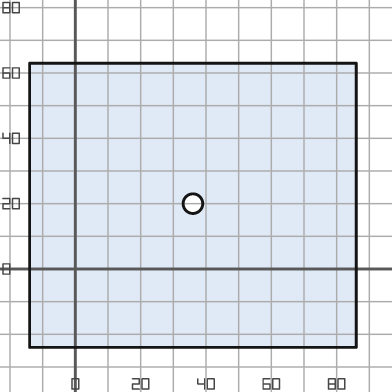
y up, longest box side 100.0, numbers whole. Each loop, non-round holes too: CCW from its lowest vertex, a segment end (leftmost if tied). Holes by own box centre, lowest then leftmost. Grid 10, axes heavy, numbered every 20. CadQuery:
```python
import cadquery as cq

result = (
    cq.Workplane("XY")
    .moveTo(-14.0, -24.0)
    .lineTo(86.0, -24.0)
    .lineTo(86.0, 63.0)
    .lineTo(-14.0, 63.0)
    .close()
    .moveTo(36.0, 20.0)
    .circle(3.0)
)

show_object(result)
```